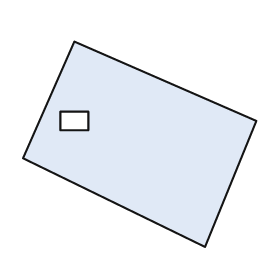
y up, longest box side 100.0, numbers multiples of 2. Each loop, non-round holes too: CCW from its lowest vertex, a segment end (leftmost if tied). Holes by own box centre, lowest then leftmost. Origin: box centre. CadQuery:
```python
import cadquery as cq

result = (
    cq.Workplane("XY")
    .moveTo(28.0, -44.0)
    .lineTo(50.0, 10.0)
    .lineTo(-28.0, 44.0)
    .lineTo(-50.0, -6.0)
    .close()
    .moveTo(-34.0, 6.0)
    .lineTo(-22.0, 6.0)
    .lineTo(-22.0, 14.0)
    .lineTo(-34.0, 14.0)
    .close()
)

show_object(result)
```